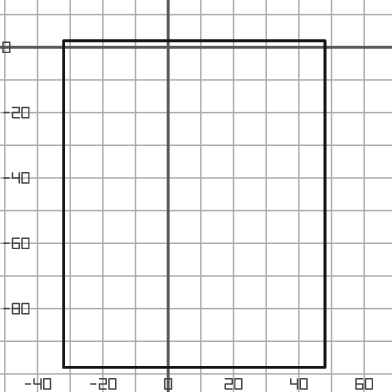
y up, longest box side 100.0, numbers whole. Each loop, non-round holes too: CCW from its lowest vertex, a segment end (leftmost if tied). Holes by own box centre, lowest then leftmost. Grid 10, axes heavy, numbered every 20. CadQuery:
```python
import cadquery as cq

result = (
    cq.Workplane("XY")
    .moveTo(-32.0, -98.0)
    .lineTo(48.0, -98.0)
    .lineTo(48.0, 2.0)
    .lineTo(-32.0, 2.0)
    .close()
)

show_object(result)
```